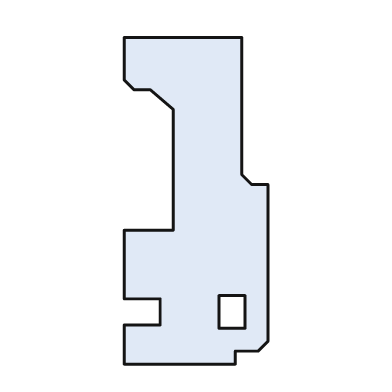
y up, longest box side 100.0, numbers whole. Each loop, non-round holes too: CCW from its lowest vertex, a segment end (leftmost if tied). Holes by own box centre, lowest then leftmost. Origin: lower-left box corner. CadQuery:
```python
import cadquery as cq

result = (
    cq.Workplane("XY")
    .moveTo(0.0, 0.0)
    .lineTo(34.0, 0.0)
    .lineTo(34.0, 4.0)
    .lineTo(41.0, 4.0)
    .lineTo(44.0, 7.0)
    .lineTo(44.0, 55.0)
    .lineTo(39.0, 55.0)
    .lineTo(36.0, 58.0)
    .lineTo(36.0, 100.0)
    .lineTo(0.0, 100.0)
    .lineTo(0.0, 87.0)
    .lineTo(3.0, 84.0)
    .lineTo(8.0, 84.0)
    .lineTo(15.0, 78.0)
    .lineTo(15.0, 41.0)
    .lineTo(0.0, 41.0)
    .lineTo(0.0, 20.0)
    .lineTo(11.0, 20.0)
    .lineTo(11.0, 12.0)
    .lineTo(0.0, 12.0)
    .close()
    .moveTo(29.0, 11.0)
    .lineTo(37.0, 11.0)
    .lineTo(37.0, 21.0)
    .lineTo(29.0, 21.0)
    .close()
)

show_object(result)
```